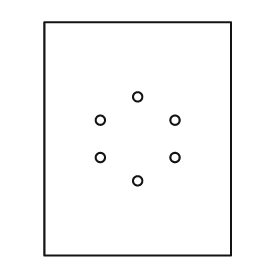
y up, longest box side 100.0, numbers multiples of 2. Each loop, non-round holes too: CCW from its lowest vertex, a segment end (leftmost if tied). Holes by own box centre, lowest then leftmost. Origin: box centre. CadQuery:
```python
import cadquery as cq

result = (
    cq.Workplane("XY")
    .moveTo(-40.0, -50.0)
    .lineTo(40.0, -50.0)
    .lineTo(40.0, 50.0)
    .lineTo(-40.0, 50.0)
    .close()
    .moveTo(0.0, -18.0)
    .circle(2.0)
    .moveTo(-16.0, -8.0)
    .circle(2.0)
    .moveTo(16.0, -8.0)
    .circle(2.0)
    .moveTo(-16.0, 8.0)
    .circle(2.0)
    .moveTo(16.0, 8.0)
    .circle(2.0)
    .moveTo(0.0, 18.0)
    .circle(2.0)
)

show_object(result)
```